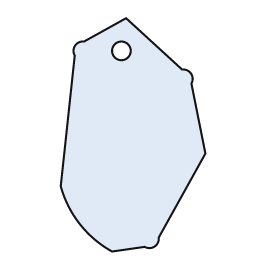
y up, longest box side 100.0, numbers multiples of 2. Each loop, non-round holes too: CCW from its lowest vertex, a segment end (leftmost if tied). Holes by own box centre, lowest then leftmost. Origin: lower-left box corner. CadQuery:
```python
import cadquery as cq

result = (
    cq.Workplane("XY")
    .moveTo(22.0, 0.0)
    .lineTo(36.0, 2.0)
    .threePointArc((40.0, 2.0), (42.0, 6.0))
    .lineTo(62.0, 42.0)
    .lineTo(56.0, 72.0)
    .threePointArc((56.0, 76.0), (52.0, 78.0))
    .lineTo(28.0, 100.0)
    .lineTo(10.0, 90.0)
    .threePointArc((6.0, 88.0), (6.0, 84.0))
    .lineTo(0.0, 28.0)
    .threePointArc((8.0, 12.0), (22.0, 0.0))
    .close()
    .moveTo(26.0, 86.0)
    .circle(4.0)
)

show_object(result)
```